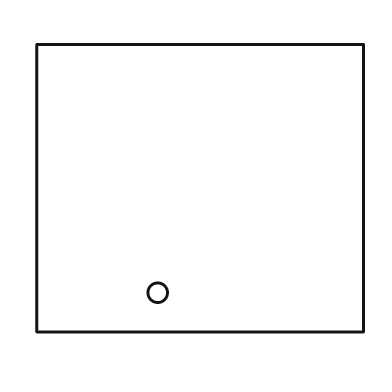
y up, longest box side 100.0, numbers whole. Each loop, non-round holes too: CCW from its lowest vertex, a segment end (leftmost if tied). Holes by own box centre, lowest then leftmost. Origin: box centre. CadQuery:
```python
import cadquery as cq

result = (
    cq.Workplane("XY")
    .moveTo(-50.0, -44.0)
    .lineTo(50.0, -44.0)
    .lineTo(50.0, 44.0)
    .lineTo(-50.0, 44.0)
    .close()
    .moveTo(-13.0, -32.0)
    .circle(3.0)
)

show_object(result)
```